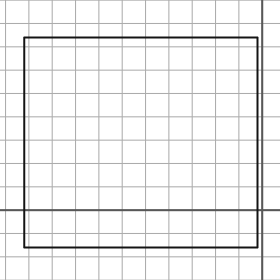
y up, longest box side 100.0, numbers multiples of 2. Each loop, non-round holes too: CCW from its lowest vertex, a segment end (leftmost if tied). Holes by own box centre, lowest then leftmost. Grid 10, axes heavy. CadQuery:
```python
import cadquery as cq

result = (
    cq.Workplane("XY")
    .moveTo(-102.0, -16.0)
    .lineTo(-2.0, -16.0)
    .lineTo(-2.0, 74.0)
    .lineTo(-102.0, 74.0)
    .close()
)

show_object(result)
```